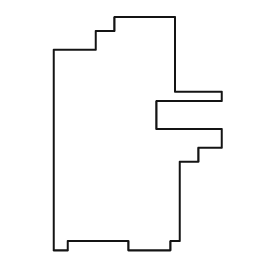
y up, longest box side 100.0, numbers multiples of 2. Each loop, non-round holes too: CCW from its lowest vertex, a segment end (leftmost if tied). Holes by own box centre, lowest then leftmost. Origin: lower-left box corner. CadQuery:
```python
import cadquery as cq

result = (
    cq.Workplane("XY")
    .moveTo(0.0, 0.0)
    .lineTo(6.0, 0.0)
    .lineTo(6.0, 4.0)
    .lineTo(32.0, 4.0)
    .lineTo(32.0, 0.0)
    .lineTo(50.0, 0.0)
    .lineTo(50.0, 4.0)
    .lineTo(54.0, 4.0)
    .lineTo(54.0, 38.0)
    .lineTo(62.0, 38.0)
    .lineTo(62.0, 44.0)
    .lineTo(72.0, 44.0)
    .lineTo(72.0, 52.0)
    .lineTo(44.0, 52.0)
    .lineTo(44.0, 64.0)
    .lineTo(72.0, 64.0)
    .lineTo(72.0, 68.0)
    .lineTo(52.0, 68.0)
    .lineTo(52.0, 100.0)
    .lineTo(26.0, 100.0)
    .lineTo(26.0, 94.0)
    .lineTo(18.0, 94.0)
    .lineTo(18.0, 86.0)
    .lineTo(0.0, 86.0)
    .close()
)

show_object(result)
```